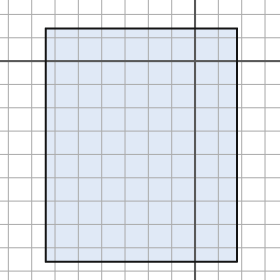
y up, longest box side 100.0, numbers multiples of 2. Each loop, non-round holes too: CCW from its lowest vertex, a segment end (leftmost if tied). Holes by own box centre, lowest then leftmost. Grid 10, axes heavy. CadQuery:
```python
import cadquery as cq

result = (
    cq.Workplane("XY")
    .moveTo(-64.0, -86.0)
    .lineTo(18.0, -86.0)
    .lineTo(18.0, 14.0)
    .lineTo(-64.0, 14.0)
    .close()
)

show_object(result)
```